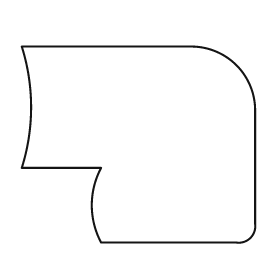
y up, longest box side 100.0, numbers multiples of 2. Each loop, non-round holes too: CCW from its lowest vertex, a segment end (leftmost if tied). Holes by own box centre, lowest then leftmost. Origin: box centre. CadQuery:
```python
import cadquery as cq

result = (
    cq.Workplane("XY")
    .moveTo(-16.0, -42.0)
    .lineTo(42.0, -42.0)
    .threePointArc((48.0, -40.0), (50.0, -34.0))
    .lineTo(50.0, 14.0)
    .threePointArc((42.0, 34.0), (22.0, 42.0))
    .lineTo(-50.0, 42.0)
    .threePointArc((-46.0, 16.0), (-50.0, -10.0))
    .lineTo(-16.0, -10.0)
    .threePointArc((-20.0, -26.0), (-16.0, -42.0))
    .close()
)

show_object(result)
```